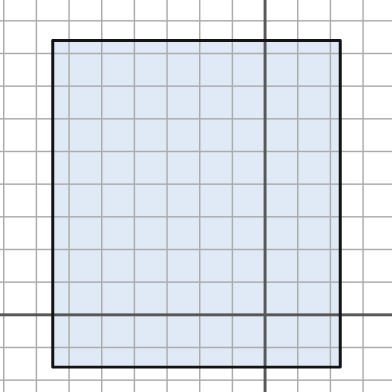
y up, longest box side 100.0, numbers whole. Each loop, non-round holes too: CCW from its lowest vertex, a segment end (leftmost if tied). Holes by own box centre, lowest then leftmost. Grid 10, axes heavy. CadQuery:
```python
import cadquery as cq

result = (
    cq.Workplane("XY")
    .moveTo(-65.0, -16.0)
    .lineTo(23.0, -16.0)
    .lineTo(23.0, 84.0)
    .lineTo(-65.0, 84.0)
    .close()
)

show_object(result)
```